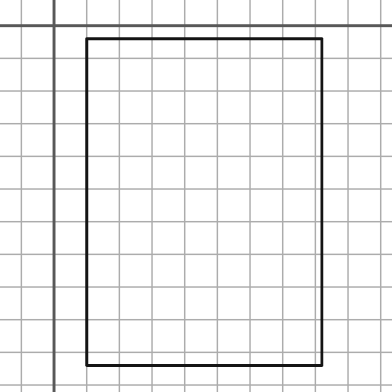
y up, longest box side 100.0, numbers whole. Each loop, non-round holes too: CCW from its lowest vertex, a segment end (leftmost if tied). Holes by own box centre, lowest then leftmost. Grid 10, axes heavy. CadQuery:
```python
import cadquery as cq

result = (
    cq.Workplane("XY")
    .moveTo(10.0, -104.0)
    .lineTo(82.0, -104.0)
    .lineTo(82.0, -4.0)
    .lineTo(10.0, -4.0)
    .close()
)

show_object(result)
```